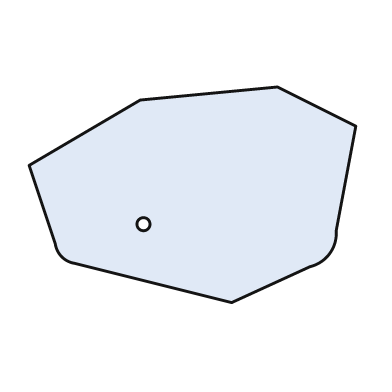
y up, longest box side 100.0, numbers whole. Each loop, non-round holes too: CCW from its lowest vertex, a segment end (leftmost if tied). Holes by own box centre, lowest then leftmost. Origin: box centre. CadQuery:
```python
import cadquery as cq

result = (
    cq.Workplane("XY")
    .moveTo(12.0, -33.0)
    .lineTo(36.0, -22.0)
    .threePointArc((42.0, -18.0), (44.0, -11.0))
    .lineTo(50.0, 21.0)
    .lineTo(26.0, 33.0)
    .lineTo(-16.0, 29.0)
    .lineTo(-50.0, 9.0)
    .lineTo(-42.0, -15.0)
    .threePointArc((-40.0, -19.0), (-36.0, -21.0))
    .close()
    .moveTo(-15.0, -9.0)
    .circle(2.0)
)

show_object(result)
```